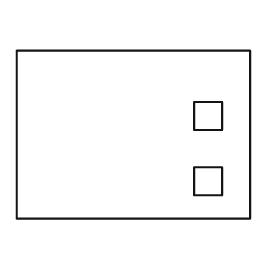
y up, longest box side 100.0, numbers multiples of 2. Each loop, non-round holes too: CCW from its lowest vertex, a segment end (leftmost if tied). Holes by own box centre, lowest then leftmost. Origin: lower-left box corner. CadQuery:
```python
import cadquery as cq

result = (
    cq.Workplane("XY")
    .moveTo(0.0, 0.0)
    .lineTo(100.0, 0.0)
    .lineTo(100.0, 72.0)
    .lineTo(0.0, 72.0)
    .close()
    .moveTo(76.0, 10.0)
    .lineTo(88.0, 10.0)
    .lineTo(88.0, 22.0)
    .lineTo(76.0, 22.0)
    .close()
    .moveTo(76.0, 38.0)
    .lineTo(88.0, 38.0)
    .lineTo(88.0, 50.0)
    .lineTo(76.0, 50.0)
    .close()
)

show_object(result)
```